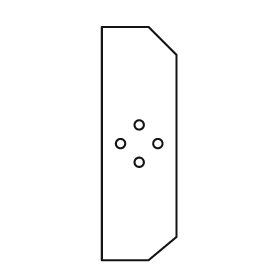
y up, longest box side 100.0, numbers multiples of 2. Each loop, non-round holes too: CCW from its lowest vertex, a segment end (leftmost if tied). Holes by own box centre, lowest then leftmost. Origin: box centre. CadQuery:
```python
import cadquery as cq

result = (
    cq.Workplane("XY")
    .moveTo(-16.0, -50.0)
    .lineTo(4.0, -50.0)
    .lineTo(16.0, -40.0)
    .lineTo(16.0, 38.0)
    .lineTo(4.0, 50.0)
    .lineTo(-16.0, 50.0)
    .close()
    .moveTo(0.0, -8.0)
    .circle(2.0)
    .moveTo(-8.0, 0.0)
    .circle(2.0)
    .moveTo(8.0, 0.0)
    .circle(2.0)
    .moveTo(0.0, 8.0)
    .circle(2.0)
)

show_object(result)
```